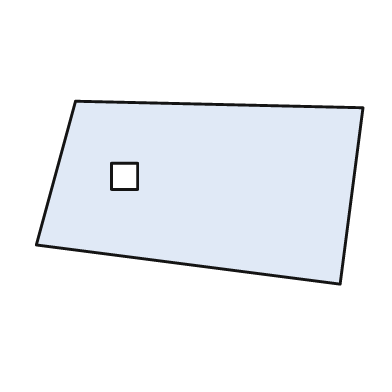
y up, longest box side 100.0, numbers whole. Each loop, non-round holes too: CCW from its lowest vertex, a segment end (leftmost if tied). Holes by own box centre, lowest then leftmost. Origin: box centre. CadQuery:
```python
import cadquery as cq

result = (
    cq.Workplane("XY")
    .moveTo(43.0, -28.0)
    .lineTo(50.0, 26.0)
    .lineTo(-38.0, 28.0)
    .lineTo(-50.0, -16.0)
    .close()
    .moveTo(-27.0, 1.0)
    .lineTo(-19.0, 1.0)
    .lineTo(-19.0, 9.0)
    .lineTo(-27.0, 9.0)
    .close()
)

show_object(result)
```